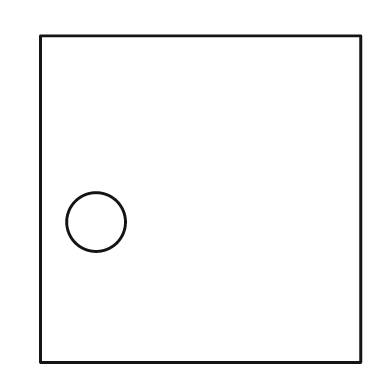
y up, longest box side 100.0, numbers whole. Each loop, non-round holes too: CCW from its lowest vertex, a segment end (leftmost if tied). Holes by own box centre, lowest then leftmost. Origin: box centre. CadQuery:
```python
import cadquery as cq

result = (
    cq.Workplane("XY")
    .moveTo(-49.0, -50.0)
    .lineTo(49.0, -50.0)
    .lineTo(49.0, 50.0)
    .lineTo(-49.0, 50.0)
    .close()
    .moveTo(-32.0, -7.0)
    .circle(9.0)
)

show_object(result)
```